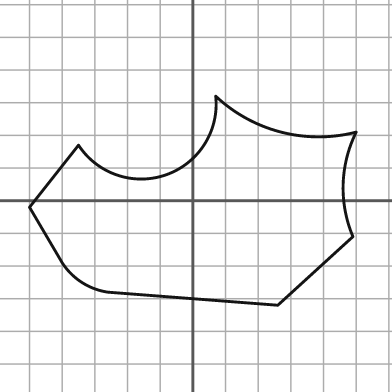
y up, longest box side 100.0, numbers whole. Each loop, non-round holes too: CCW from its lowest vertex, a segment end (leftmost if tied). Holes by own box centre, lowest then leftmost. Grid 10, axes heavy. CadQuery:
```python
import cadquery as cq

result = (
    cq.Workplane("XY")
    .moveTo(26.0, -32.0)
    .lineTo(49.0, -11.0)
    .threePointArc((46.0, 5.0), (50.0, 21.0))
    .threePointArc((27.0, 21.0), (7.0, 32.0))
    .threePointArc((-8.0, 8.0), (-35.0, 17.0))
    .lineTo(-50.0, -2.0)
    .lineTo(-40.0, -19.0)
    .threePointArc((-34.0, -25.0), (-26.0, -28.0))
    .close()
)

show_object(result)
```